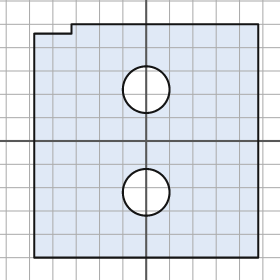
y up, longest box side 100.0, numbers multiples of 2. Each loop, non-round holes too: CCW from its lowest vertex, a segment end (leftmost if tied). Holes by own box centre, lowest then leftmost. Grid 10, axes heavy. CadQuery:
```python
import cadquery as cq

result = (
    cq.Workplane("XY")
    .moveTo(-48.0, -50.0)
    .lineTo(48.0, -50.0)
    .lineTo(48.0, 50.0)
    .lineTo(-32.0, 50.0)
    .lineTo(-32.0, 46.0)
    .lineTo(-48.0, 46.0)
    .close()
    .moveTo(0.0, -22.0)
    .circle(10.0)
    .moveTo(0.0, 22.0)
    .circle(10.0)
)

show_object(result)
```